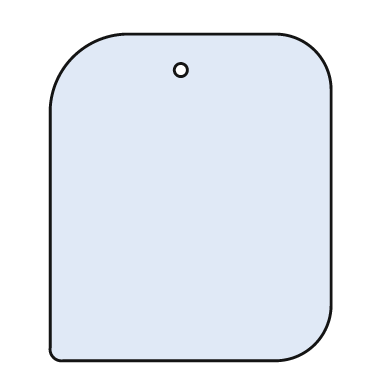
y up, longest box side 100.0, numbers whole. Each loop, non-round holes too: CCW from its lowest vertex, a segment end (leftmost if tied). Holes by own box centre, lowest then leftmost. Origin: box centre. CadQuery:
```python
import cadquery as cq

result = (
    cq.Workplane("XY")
    .moveTo(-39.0, -50.0)
    .lineTo(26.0, -50.0)
    .threePointArc((38.0, -45.0), (43.0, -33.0))
    .lineTo(43.0, 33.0)
    .threePointArc((38.0, 45.0), (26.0, 50.0))
    .lineTo(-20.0, 50.0)
    .threePointArc((-36.0, 43.0), (-43.0, 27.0))
    .lineTo(-43.0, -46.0)
    .threePointArc((-42.0, -49.0), (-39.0, -50.0))
    .close()
    .moveTo(-3.0, 39.0)
    .circle(2.0)
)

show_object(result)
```